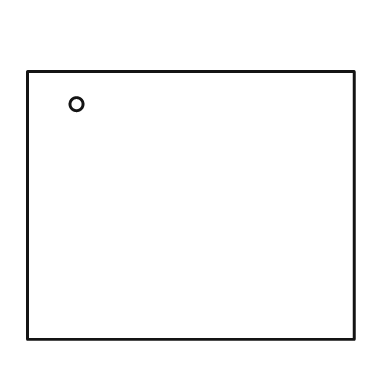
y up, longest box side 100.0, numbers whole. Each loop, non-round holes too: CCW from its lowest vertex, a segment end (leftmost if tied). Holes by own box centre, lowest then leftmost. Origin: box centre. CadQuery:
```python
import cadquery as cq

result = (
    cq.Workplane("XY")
    .moveTo(-50.0, -41.0)
    .lineTo(50.0, -41.0)
    .lineTo(50.0, 41.0)
    .lineTo(-50.0, 41.0)
    .close()
    .moveTo(-35.0, 31.0)
    .circle(2.0)
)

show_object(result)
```